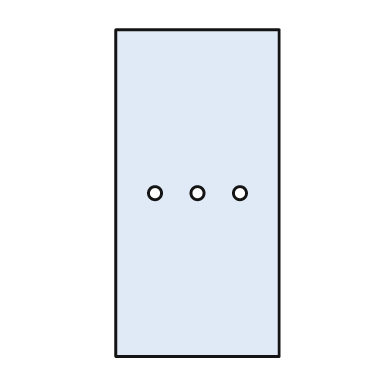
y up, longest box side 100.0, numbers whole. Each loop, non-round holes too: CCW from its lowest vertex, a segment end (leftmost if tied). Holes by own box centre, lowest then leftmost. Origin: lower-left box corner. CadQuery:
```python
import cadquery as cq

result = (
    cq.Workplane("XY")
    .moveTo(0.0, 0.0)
    .lineTo(50.0, 0.0)
    .lineTo(50.0, 100.0)
    .lineTo(0.0, 100.0)
    .close()
    .moveTo(12.0, 50.0)
    .circle(2.0)
    .moveTo(25.0, 50.0)
    .circle(2.0)
    .moveTo(38.0, 50.0)
    .circle(2.0)
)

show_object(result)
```